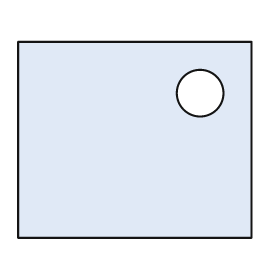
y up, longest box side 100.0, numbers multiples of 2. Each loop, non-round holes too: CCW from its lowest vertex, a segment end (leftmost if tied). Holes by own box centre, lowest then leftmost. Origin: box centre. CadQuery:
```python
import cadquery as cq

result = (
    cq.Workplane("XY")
    .moveTo(-50.0, -42.0)
    .lineTo(50.0, -42.0)
    .lineTo(50.0, 42.0)
    .lineTo(-50.0, 42.0)
    .close()
    .moveTo(28.0, 20.0)
    .circle(10.0)
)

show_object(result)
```